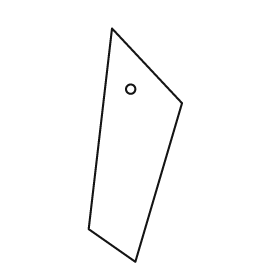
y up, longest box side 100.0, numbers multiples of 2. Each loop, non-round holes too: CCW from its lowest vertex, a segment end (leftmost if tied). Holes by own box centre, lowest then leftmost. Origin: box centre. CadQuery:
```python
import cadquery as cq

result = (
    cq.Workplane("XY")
    .moveTo(0.0, -50.0)
    .lineTo(20.0, 18.0)
    .lineTo(-10.0, 50.0)
    .lineTo(-20.0, -36.0)
    .close()
    .moveTo(-2.0, 24.0)
    .circle(2.0)
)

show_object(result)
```